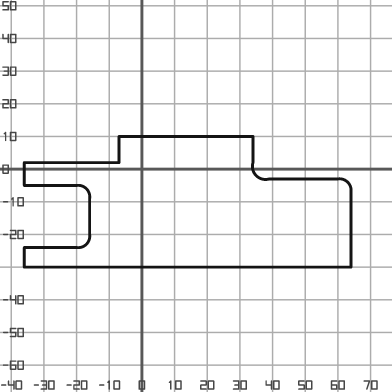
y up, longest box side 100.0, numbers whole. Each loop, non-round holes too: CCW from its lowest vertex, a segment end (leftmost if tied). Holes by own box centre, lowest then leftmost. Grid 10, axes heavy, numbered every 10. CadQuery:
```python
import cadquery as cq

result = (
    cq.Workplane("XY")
    .moveTo(-36.0, -30.0)
    .lineTo(64.0, -30.0)
    .lineTo(64.0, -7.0)
    .threePointArc((63.0, -4.0), (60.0, -3.0))
    .lineTo(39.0, -3.0)
    .threePointArc((35.0, -2.0), (34.0, 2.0))
    .lineTo(34.0, 10.0)
    .lineTo(-7.0, 10.0)
    .lineTo(-7.0, 2.0)
    .lineTo(-36.0, 2.0)
    .lineTo(-36.0, -5.0)
    .lineTo(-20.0, -5.0)
    .threePointArc((-17.0, -6.0), (-16.0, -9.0))
    .lineTo(-16.0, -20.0)
    .threePointArc((-17.0, -23.0), (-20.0, -24.0))
    .lineTo(-36.0, -24.0)
    .close()
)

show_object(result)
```